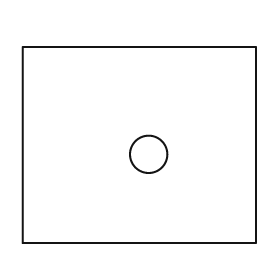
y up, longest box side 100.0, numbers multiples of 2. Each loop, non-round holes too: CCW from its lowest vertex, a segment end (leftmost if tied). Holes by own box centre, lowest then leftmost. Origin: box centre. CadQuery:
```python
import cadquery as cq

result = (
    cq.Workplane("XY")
    .moveTo(-50.0, -42.0)
    .lineTo(50.0, -42.0)
    .lineTo(50.0, 42.0)
    .lineTo(-50.0, 42.0)
    .close()
    .moveTo(4.0, -4.0)
    .circle(8.0)
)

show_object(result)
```